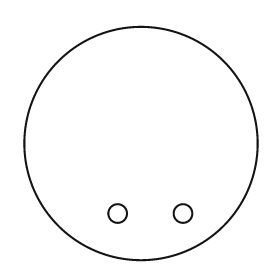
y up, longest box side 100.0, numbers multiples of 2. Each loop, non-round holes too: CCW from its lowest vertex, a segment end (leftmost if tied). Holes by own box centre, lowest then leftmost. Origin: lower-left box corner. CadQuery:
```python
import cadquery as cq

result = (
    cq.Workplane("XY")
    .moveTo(50.0, 50.0)
    .circle(50.0)
    .moveTo(40.0, 20.0)
    .circle(4.0)
    .moveTo(68.0, 20.0)
    .circle(4.0)
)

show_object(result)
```